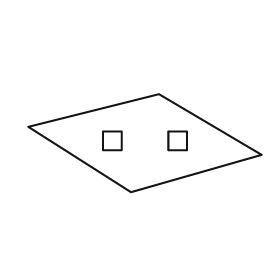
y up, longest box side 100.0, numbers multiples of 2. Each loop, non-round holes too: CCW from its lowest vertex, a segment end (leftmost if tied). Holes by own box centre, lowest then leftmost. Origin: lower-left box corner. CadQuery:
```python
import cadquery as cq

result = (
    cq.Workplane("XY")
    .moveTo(44.0, 0.0)
    .lineTo(100.0, 16.0)
    .lineTo(56.0, 42.0)
    .lineTo(0.0, 28.0)
    .close()
    .moveTo(32.0, 18.0)
    .lineTo(40.0, 18.0)
    .lineTo(40.0, 26.0)
    .lineTo(32.0, 26.0)
    .close()
    .moveTo(60.0, 18.0)
    .lineTo(68.0, 18.0)
    .lineTo(68.0, 26.0)
    .lineTo(60.0, 26.0)
    .close()
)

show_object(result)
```